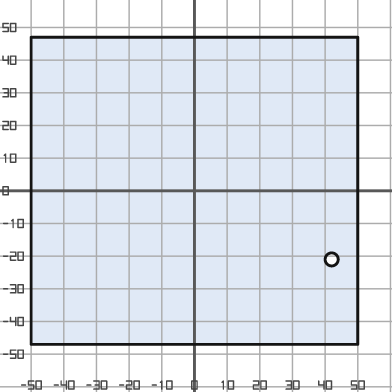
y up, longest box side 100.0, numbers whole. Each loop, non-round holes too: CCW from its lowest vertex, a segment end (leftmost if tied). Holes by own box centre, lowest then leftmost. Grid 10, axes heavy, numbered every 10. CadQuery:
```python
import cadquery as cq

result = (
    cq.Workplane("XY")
    .moveTo(-50.0, -47.0)
    .lineTo(50.0, -47.0)
    .lineTo(50.0, 47.0)
    .lineTo(-50.0, 47.0)
    .close()
    .moveTo(42.0, -21.0)
    .circle(2.0)
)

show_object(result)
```